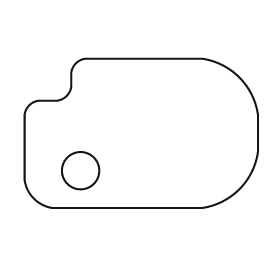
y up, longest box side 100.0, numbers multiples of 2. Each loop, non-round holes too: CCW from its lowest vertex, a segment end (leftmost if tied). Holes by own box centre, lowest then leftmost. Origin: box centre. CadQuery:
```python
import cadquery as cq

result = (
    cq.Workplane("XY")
    .moveTo(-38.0, -32.0)
    .lineTo(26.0, -32.0)
    .threePointArc((42.0, -24.0), (50.0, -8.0))
    .lineTo(50.0, 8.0)
    .threePointArc((42.0, 24.0), (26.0, 32.0))
    .lineTo(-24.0, 32.0)
    .threePointArc((-28.0, 30.0), (-30.0, 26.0))
    .lineTo(-30.0, 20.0)
    .threePointArc((-32.0, 16.0), (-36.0, 14.0))
    .lineTo(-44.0, 14.0)
    .threePointArc((-48.0, 12.0), (-50.0, 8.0))
    .lineTo(-50.0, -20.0)
    .threePointArc((-46.0, -28.0), (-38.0, -32.0))
    .close()
    .moveTo(-26.0, -16.0)
    .circle(8.0)
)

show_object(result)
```